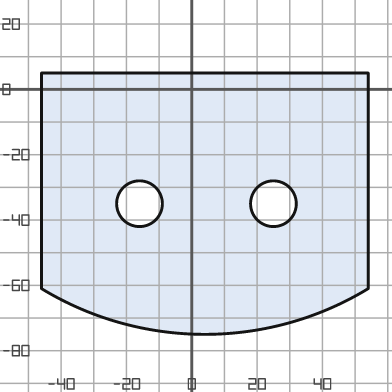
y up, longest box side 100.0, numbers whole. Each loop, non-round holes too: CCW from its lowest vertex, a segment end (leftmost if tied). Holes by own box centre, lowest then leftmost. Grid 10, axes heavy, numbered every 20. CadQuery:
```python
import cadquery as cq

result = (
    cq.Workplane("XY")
    .moveTo(-46.0, -61.0)
    .threePointArc((4.0, -75.0), (54.0, -61.0))
    .lineTo(54.0, 5.0)
    .lineTo(-46.0, 5.0)
    .close()
    .moveTo(-16.0, -35.0)
    .circle(7.0)
    .moveTo(25.0, -35.0)
    .circle(7.0)
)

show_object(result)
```